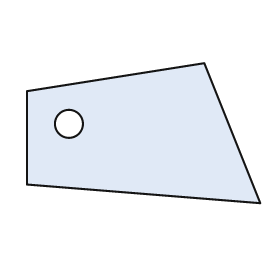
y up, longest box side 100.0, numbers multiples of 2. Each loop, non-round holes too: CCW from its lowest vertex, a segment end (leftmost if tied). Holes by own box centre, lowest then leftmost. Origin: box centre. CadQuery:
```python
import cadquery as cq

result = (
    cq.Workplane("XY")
    .moveTo(50.0, -30.0)
    .lineTo(26.0, 30.0)
    .lineTo(-50.0, 18.0)
    .lineTo(-50.0, -22.0)
    .close()
    .moveTo(-32.0, 4.0)
    .circle(6.0)
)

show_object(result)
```